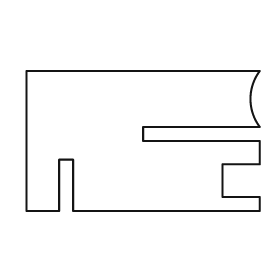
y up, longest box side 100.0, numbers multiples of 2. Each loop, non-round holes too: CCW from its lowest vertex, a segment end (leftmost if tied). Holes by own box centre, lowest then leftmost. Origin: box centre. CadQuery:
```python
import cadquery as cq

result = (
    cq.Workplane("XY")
    .moveTo(-50.0, -30.0)
    .lineTo(-36.0, -30.0)
    .lineTo(-36.0, -8.0)
    .lineTo(-30.0, -8.0)
    .lineTo(-30.0, -30.0)
    .lineTo(50.0, -30.0)
    .lineTo(50.0, -24.0)
    .lineTo(34.0, -24.0)
    .lineTo(34.0, -10.0)
    .lineTo(50.0, -10.0)
    .lineTo(50.0, 0.0)
    .lineTo(0.0, 0.0)
    .lineTo(0.0, 6.0)
    .lineTo(50.0, 6.0)
    .threePointArc((46.0, 18.0), (50.0, 30.0))
    .lineTo(-50.0, 30.0)
    .close()
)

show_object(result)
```